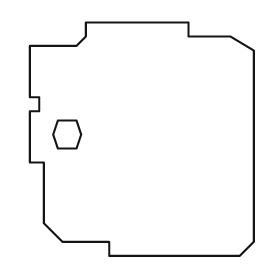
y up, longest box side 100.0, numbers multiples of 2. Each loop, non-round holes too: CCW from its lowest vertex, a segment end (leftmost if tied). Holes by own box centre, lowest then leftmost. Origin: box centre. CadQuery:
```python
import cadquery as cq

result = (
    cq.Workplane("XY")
    .moveTo(-14.0, -50.0)
    .lineTo(42.0, -50.0)
    .lineTo(48.0, -44.0)
    .lineTo(48.0, 38.0)
    .lineTo(38.0, 44.0)
    .lineTo(20.0, 44.0)
    .lineTo(20.0, 50.0)
    .lineTo(-24.0, 50.0)
    .lineTo(-24.0, 44.0)
    .lineTo(-28.0, 40.0)
    .lineTo(-48.0, 40.0)
    .lineTo(-48.0, 18.0)
    .lineTo(-44.0, 18.0)
    .lineTo(-44.0, 12.0)
    .lineTo(-48.0, 12.0)
    .lineTo(-48.0, -10.0)
    .lineTo(-42.0, -10.0)
    .lineTo(-42.0, -36.0)
    .lineTo(-34.0, -44.0)
    .lineTo(-14.0, -44.0)
    .close()
    .moveTo(-36.0, -4.0)
    .lineTo(-28.0, -4.0)
    .lineTo(-26.0, 2.0)
    .lineTo(-28.0, 8.0)
    .lineTo(-36.0, 8.0)
    .lineTo(-38.0, 2.0)
    .close()
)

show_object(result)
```